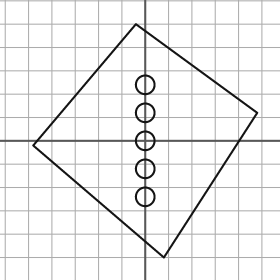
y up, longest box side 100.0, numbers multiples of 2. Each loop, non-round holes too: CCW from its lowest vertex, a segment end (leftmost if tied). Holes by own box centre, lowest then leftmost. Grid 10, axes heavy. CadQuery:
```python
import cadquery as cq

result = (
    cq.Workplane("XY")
    .moveTo(8.0, -50.0)
    .lineTo(48.0, 12.0)
    .lineTo(-4.0, 50.0)
    .lineTo(-48.0, -2.0)
    .close()
    .moveTo(0.0, -24.0)
    .circle(4.0)
    .moveTo(0.0, -12.0)
    .circle(4.0)
    .moveTo(0.0, 0.0)
    .circle(4.0)
    .moveTo(0.0, 12.0)
    .circle(4.0)
    .moveTo(0.0, 24.0)
    .circle(4.0)
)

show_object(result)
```